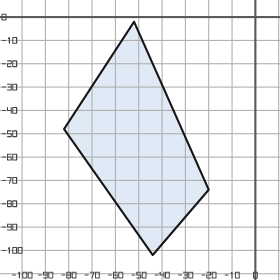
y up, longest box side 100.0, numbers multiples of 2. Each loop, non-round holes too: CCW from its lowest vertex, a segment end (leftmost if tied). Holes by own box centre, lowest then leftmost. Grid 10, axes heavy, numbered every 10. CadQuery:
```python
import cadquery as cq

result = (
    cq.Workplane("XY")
    .moveTo(-44.0, -102.0)
    .lineTo(-20.0, -74.0)
    .lineTo(-52.0, -2.0)
    .lineTo(-82.0, -48.0)
    .close()
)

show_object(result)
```